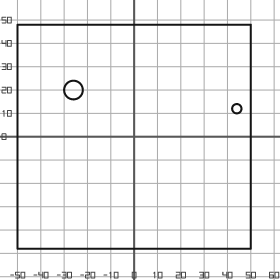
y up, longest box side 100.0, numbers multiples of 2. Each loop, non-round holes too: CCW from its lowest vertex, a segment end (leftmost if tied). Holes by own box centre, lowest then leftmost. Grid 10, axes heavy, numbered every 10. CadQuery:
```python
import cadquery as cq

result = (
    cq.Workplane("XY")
    .moveTo(-50.0, -48.0)
    .lineTo(50.0, -48.0)
    .lineTo(50.0, 48.0)
    .lineTo(-50.0, 48.0)
    .close()
    .moveTo(44.0, 12.0)
    .circle(2.0)
    .moveTo(-26.0, 20.0)
    .circle(4.0)
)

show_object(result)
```